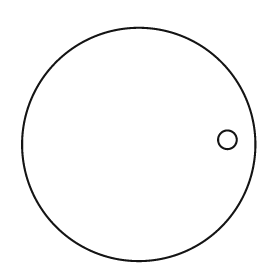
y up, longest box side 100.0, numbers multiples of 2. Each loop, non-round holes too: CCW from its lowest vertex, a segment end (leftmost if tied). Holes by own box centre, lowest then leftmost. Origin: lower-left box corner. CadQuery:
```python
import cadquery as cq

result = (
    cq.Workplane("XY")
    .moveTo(50.0, 50.0)
    .circle(50.0)
    .moveTo(88.0, 52.0)
    .circle(4.0)
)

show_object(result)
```